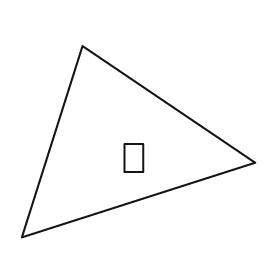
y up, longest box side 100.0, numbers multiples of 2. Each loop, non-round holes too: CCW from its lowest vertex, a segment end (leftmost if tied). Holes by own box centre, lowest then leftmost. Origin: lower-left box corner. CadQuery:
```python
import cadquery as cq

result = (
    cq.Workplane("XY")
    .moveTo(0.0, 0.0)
    .lineTo(100.0, 32.0)
    .lineTo(26.0, 82.0)
    .close()
    .moveTo(44.0, 28.0)
    .lineTo(52.0, 28.0)
    .lineTo(52.0, 40.0)
    .lineTo(44.0, 40.0)
    .close()
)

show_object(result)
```